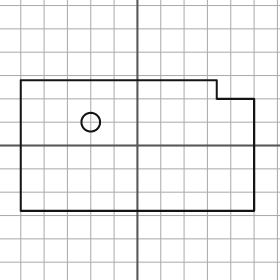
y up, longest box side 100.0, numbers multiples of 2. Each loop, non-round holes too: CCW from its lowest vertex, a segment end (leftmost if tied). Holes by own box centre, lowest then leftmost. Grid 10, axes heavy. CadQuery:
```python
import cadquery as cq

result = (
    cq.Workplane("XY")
    .moveTo(-50.0, -28.0)
    .lineTo(50.0, -28.0)
    .lineTo(50.0, 20.0)
    .lineTo(34.0, 20.0)
    .lineTo(34.0, 28.0)
    .lineTo(-50.0, 28.0)
    .close()
    .moveTo(-20.0, 10.0)
    .circle(4.0)
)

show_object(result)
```